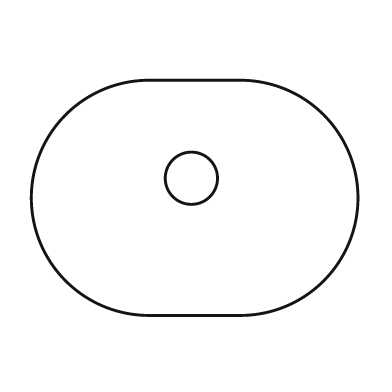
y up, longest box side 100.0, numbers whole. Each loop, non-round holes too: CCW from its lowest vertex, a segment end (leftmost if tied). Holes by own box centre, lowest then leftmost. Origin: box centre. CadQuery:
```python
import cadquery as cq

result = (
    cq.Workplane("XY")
    .moveTo(-14.0, -36.0)
    .lineTo(14.0, -36.0)
    .threePointArc((50.0, 0.0), (14.0, 36.0))
    .lineTo(-14.0, 36.0)
    .threePointArc((-50.0, 0.0), (-14.0, -36.0))
    .close()
    .moveTo(-1.0, 6.0)
    .circle(8.0)
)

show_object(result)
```